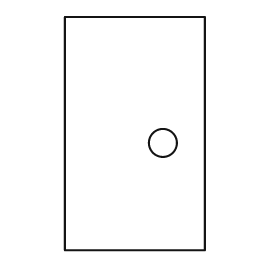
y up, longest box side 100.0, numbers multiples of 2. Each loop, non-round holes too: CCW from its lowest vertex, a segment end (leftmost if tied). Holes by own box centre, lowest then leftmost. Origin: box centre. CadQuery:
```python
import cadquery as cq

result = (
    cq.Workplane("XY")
    .moveTo(-30.0, -50.0)
    .lineTo(30.0, -50.0)
    .lineTo(30.0, 50.0)
    .lineTo(-30.0, 50.0)
    .close()
    .moveTo(12.0, -4.0)
    .circle(6.0)
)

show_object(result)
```